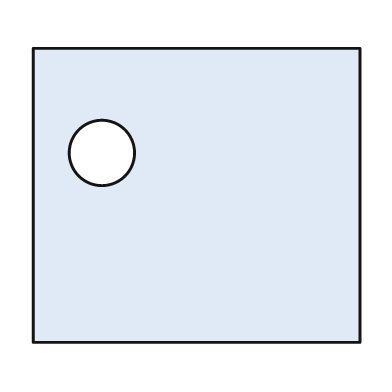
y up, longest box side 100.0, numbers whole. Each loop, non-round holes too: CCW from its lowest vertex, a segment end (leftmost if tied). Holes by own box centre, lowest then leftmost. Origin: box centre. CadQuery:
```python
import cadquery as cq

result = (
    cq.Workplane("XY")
    .moveTo(-50.0, -45.0)
    .lineTo(50.0, -45.0)
    .lineTo(50.0, 45.0)
    .lineTo(-50.0, 45.0)
    .close()
    .moveTo(-29.0, 13.0)
    .circle(10.0)
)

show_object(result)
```